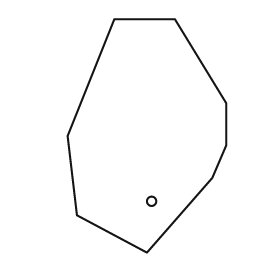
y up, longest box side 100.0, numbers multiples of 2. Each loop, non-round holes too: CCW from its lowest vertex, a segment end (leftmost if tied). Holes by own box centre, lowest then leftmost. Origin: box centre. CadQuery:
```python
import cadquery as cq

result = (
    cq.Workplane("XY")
    .moveTo(0.0, -50.0)
    .lineTo(28.0, -18.0)
    .lineTo(34.0, -4.0)
    .lineTo(34.0, 14.0)
    .lineTo(12.0, 50.0)
    .lineTo(-14.0, 50.0)
    .lineTo(-34.0, 0.0)
    .lineTo(-30.0, -34.0)
    .close()
    .moveTo(2.0, -28.0)
    .circle(2.0)
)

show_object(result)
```